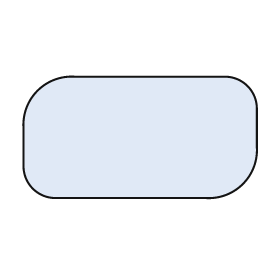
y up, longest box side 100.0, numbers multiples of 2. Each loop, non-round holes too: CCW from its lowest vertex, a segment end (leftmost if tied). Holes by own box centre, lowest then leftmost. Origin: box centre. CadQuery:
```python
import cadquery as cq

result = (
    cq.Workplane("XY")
    .moveTo(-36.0, -26.0)
    .lineTo(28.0, -26.0)
    .threePointArc((44.0, -20.0), (50.0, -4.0))
    .lineTo(50.0, 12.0)
    .threePointArc((46.0, 22.0), (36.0, 26.0))
    .lineTo(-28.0, 26.0)
    .threePointArc((-44.0, 20.0), (-50.0, 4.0))
    .lineTo(-50.0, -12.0)
    .threePointArc((-46.0, -22.0), (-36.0, -26.0))
    .close()
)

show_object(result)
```